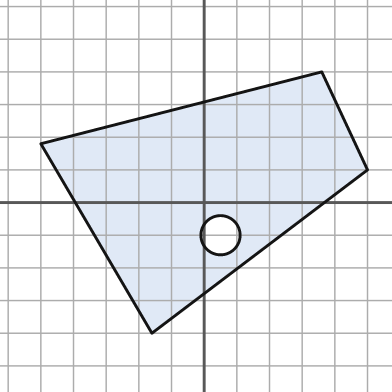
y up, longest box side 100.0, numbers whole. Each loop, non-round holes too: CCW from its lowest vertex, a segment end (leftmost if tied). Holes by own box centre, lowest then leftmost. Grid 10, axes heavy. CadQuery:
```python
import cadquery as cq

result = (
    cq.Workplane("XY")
    .moveTo(-16.0, -40.0)
    .lineTo(50.0, 10.0)
    .lineTo(36.0, 40.0)
    .lineTo(-50.0, 18.0)
    .close()
    .moveTo(5.0, -10.0)
    .circle(6.0)
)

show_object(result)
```